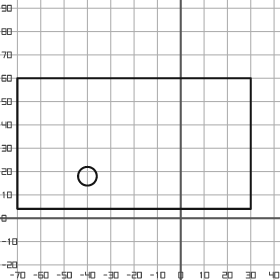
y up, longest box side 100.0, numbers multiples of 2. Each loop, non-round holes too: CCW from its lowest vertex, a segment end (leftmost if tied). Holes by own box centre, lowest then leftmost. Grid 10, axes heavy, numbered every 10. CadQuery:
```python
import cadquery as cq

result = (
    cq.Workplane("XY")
    .moveTo(-70.0, 4.0)
    .lineTo(30.0, 4.0)
    .lineTo(30.0, 60.0)
    .lineTo(-70.0, 60.0)
    .close()
    .moveTo(-40.0, 18.0)
    .circle(4.0)
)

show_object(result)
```